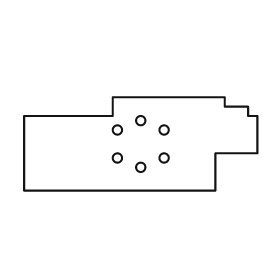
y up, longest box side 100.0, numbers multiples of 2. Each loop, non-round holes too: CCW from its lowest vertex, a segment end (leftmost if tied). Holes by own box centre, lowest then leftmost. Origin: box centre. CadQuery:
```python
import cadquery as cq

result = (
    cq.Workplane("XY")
    .moveTo(-50.0, -20.0)
    .lineTo(32.0, -20.0)
    .lineTo(32.0, -4.0)
    .lineTo(50.0, -4.0)
    .lineTo(50.0, 12.0)
    .lineTo(46.0, 12.0)
    .lineTo(46.0, 16.0)
    .lineTo(36.0, 16.0)
    .lineTo(36.0, 20.0)
    .lineTo(-12.0, 20.0)
    .lineTo(-12.0, 12.0)
    .lineTo(-50.0, 12.0)
    .close()
    .moveTo(0.0, -10.0)
    .circle(2.0)
    .moveTo(-10.0, -6.0)
    .circle(2.0)
    .moveTo(10.0, -6.0)
    .circle(2.0)
    .moveTo(-10.0, 6.0)
    .circle(2.0)
    .moveTo(10.0, 6.0)
    .circle(2.0)
    .moveTo(0.0, 10.0)
    .circle(2.0)
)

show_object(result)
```